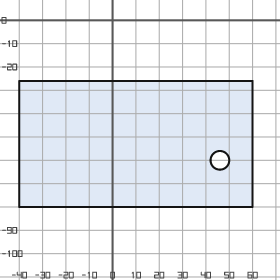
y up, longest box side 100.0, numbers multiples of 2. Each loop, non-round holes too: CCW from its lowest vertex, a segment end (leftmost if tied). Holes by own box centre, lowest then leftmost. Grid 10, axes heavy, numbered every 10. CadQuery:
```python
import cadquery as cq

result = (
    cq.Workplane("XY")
    .moveTo(-40.0, -80.0)
    .lineTo(60.0, -80.0)
    .lineTo(60.0, -26.0)
    .lineTo(-40.0, -26.0)
    .close()
    .moveTo(46.0, -60.0)
    .circle(4.0)
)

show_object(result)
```